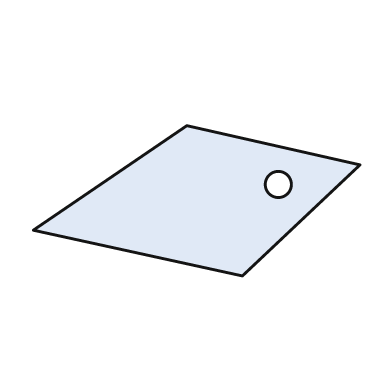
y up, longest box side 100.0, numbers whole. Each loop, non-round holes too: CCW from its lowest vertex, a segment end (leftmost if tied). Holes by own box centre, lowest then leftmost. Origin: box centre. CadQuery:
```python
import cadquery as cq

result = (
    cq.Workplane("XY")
    .moveTo(14.0, -23.0)
    .lineTo(50.0, 11.0)
    .lineTo(-3.0, 23.0)
    .lineTo(-50.0, -9.0)
    .close()
    .moveTo(25.0, 5.0)
    .circle(4.0)
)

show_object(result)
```